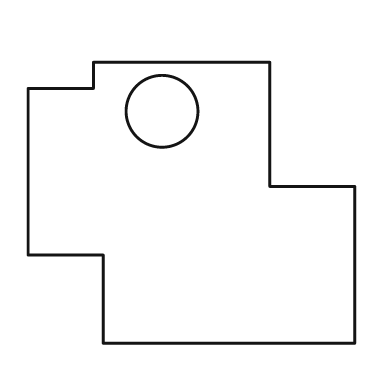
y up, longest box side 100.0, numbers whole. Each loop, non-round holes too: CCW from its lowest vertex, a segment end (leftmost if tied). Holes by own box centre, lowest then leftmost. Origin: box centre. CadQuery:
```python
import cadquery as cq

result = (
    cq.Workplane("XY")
    .moveTo(-27.0, -43.0)
    .lineTo(50.0, -43.0)
    .lineTo(50.0, 5.0)
    .lineTo(24.0, 5.0)
    .lineTo(24.0, 43.0)
    .lineTo(-30.0, 43.0)
    .lineTo(-30.0, 35.0)
    .lineTo(-50.0, 35.0)
    .lineTo(-50.0, -16.0)
    .lineTo(-27.0, -16.0)
    .close()
    .moveTo(-9.0, 28.0)
    .circle(11.0)
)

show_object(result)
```